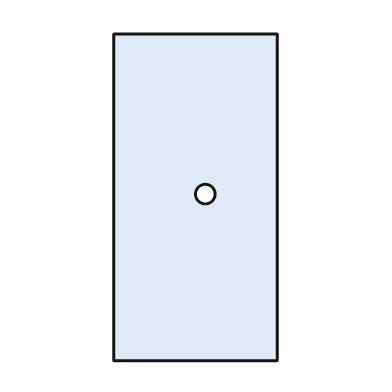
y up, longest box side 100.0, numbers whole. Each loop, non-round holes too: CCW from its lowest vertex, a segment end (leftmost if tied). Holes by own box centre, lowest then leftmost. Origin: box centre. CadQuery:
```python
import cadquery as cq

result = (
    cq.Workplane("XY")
    .moveTo(-25.0, -50.0)
    .lineTo(25.0, -50.0)
    .lineTo(25.0, 50.0)
    .lineTo(-25.0, 50.0)
    .close()
    .moveTo(3.0, 1.0)
    .circle(3.0)
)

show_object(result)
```